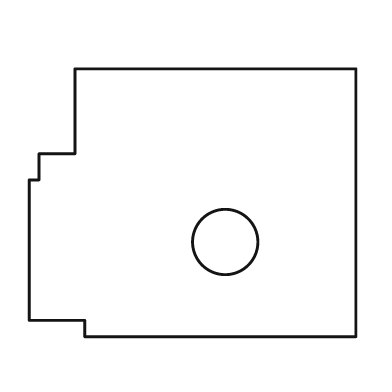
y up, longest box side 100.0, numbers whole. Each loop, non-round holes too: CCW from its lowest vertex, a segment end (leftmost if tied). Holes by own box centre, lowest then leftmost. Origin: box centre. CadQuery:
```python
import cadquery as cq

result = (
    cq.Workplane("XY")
    .moveTo(-33.0, -41.0)
    .lineTo(50.0, -41.0)
    .lineTo(50.0, 41.0)
    .lineTo(-36.0, 41.0)
    .lineTo(-36.0, 15.0)
    .lineTo(-47.0, 15.0)
    .lineTo(-47.0, 7.0)
    .lineTo(-50.0, 7.0)
    .lineTo(-50.0, -36.0)
    .lineTo(-33.0, -36.0)
    .close()
    .moveTo(10.0, -12.0)
    .circle(10.0)
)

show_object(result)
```